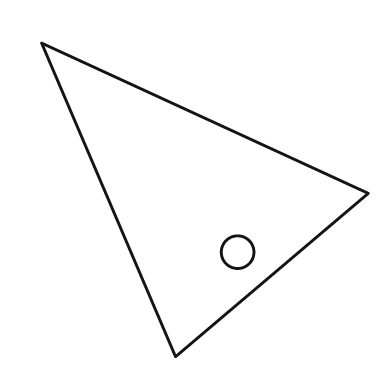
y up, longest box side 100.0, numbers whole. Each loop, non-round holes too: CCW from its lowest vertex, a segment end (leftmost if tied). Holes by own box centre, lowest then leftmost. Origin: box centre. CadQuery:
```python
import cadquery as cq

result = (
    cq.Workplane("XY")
    .moveTo(-9.0, -48.0)
    .lineTo(50.0, 2.0)
    .lineTo(-50.0, 48.0)
    .close()
    .moveTo(10.0, -16.0)
    .circle(5.0)
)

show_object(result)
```